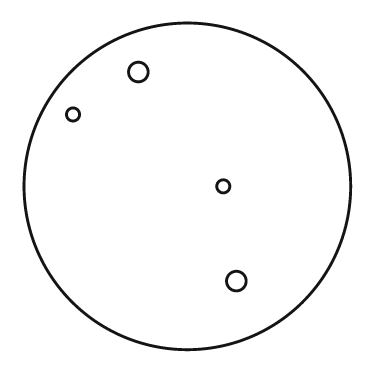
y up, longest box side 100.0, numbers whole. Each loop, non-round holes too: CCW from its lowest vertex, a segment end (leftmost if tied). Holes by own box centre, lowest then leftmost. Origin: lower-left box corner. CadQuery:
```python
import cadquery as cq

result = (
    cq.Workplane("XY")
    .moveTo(50.0, 50.0)
    .circle(50.0)
    .moveTo(65.0, 21.0)
    .circle(3.0)
    .moveTo(61.0, 50.0)
    .circle(2.0)
    .moveTo(15.0, 72.0)
    .circle(2.0)
    .moveTo(35.0, 85.0)
    .circle(3.0)
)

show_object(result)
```